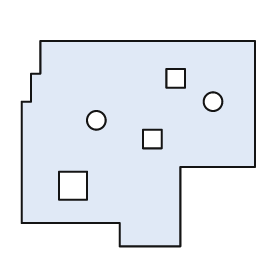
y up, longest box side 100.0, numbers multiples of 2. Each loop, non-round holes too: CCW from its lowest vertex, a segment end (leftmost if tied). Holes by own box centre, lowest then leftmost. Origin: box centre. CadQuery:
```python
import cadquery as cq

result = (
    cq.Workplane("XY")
    .moveTo(-8.0, -44.0)
    .lineTo(18.0, -44.0)
    .lineTo(18.0, -10.0)
    .lineTo(50.0, -10.0)
    .lineTo(50.0, 44.0)
    .lineTo(-42.0, 44.0)
    .lineTo(-42.0, 30.0)
    .lineTo(-46.0, 30.0)
    .lineTo(-46.0, 18.0)
    .lineTo(-50.0, 18.0)
    .lineTo(-50.0, -34.0)
    .lineTo(-8.0, -34.0)
    .close()
    .moveTo(-34.0, -24.0)
    .lineTo(-22.0, -24.0)
    .lineTo(-22.0, -12.0)
    .lineTo(-34.0, -12.0)
    .close()
    .moveTo(2.0, -2.0)
    .lineTo(10.0, -2.0)
    .lineTo(10.0, 6.0)
    .lineTo(2.0, 6.0)
    .close()
    .moveTo(-18.0, 10.0)
    .circle(4.0)
    .moveTo(32.0, 18.0)
    .circle(4.0)
    .moveTo(12.0, 24.0)
    .lineTo(20.0, 24.0)
    .lineTo(20.0, 32.0)
    .lineTo(12.0, 32.0)
    .close()
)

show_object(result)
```